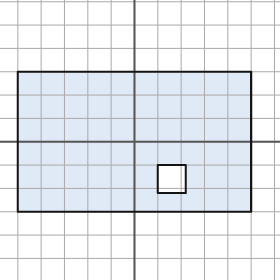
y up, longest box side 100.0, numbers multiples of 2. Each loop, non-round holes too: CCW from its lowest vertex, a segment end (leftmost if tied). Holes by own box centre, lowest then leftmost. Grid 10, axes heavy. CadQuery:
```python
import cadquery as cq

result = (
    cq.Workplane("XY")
    .moveTo(-50.0, -30.0)
    .lineTo(50.0, -30.0)
    .lineTo(50.0, 30.0)
    .lineTo(-50.0, 30.0)
    .close()
    .moveTo(10.0, -22.0)
    .lineTo(22.0, -22.0)
    .lineTo(22.0, -10.0)
    .lineTo(10.0, -10.0)
    .close()
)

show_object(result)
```